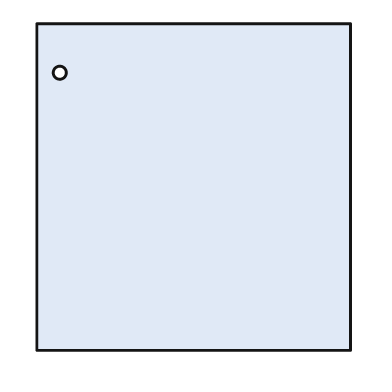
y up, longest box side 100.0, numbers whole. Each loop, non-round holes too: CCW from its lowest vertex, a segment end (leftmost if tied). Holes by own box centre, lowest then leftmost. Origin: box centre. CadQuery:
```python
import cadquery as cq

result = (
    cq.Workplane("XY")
    .moveTo(-48.0, -50.0)
    .lineTo(48.0, -50.0)
    .lineTo(48.0, 50.0)
    .lineTo(-48.0, 50.0)
    .close()
    .moveTo(-41.0, 35.0)
    .circle(2.0)
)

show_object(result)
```